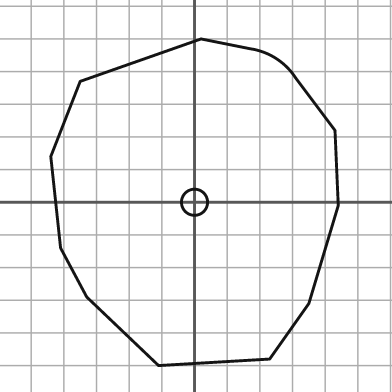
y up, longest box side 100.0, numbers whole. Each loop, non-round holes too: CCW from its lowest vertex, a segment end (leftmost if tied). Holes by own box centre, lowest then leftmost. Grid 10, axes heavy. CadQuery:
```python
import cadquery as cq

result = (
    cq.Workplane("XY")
    .moveTo(-11.0, -50.0)
    .lineTo(23.0, -48.0)
    .lineTo(35.0, -31.0)
    .lineTo(44.0, -1.0)
    .lineTo(43.0, 22.0)
    .lineTo(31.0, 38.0)
    .threePointArc((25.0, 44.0), (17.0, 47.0))
    .lineTo(2.0, 50.0)
    .lineTo(-35.0, 37.0)
    .lineTo(-44.0, 14.0)
    .lineTo(-41.0, -14.0)
    .lineTo(-33.0, -29.0)
    .close()
    .moveTo(0.0, 0.0)
    .circle(4.0)
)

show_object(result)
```